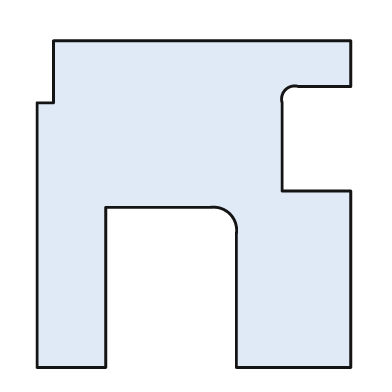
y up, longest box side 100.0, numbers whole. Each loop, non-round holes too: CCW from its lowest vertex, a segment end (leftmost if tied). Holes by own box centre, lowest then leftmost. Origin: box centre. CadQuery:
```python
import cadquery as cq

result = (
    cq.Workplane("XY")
    .moveTo(-48.0, -50.0)
    .lineTo(-27.0, -50.0)
    .lineTo(-27.0, -1.0)
    .lineTo(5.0, -1.0)
    .threePointArc((11.0, -3.0), (13.0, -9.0))
    .lineTo(13.0, -50.0)
    .lineTo(48.0, -50.0)
    .lineTo(48.0, 4.0)
    .lineTo(27.0, 4.0)
    .lineTo(27.0, 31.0)
    .threePointArc((28.0, 35.0), (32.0, 36.0))
    .lineTo(48.0, 36.0)
    .lineTo(48.0, 50.0)
    .lineTo(-43.0, 50.0)
    .lineTo(-43.0, 31.0)
    .lineTo(-48.0, 31.0)
    .close()
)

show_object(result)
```